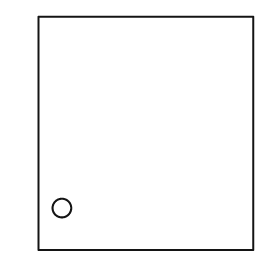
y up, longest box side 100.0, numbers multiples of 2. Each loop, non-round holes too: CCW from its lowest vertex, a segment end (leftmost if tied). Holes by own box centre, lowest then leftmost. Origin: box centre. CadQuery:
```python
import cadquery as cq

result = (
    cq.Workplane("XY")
    .moveTo(-46.0, -50.0)
    .lineTo(46.0, -50.0)
    .lineTo(46.0, 50.0)
    .lineTo(-46.0, 50.0)
    .close()
    .moveTo(-36.0, -32.0)
    .circle(4.0)
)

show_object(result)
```